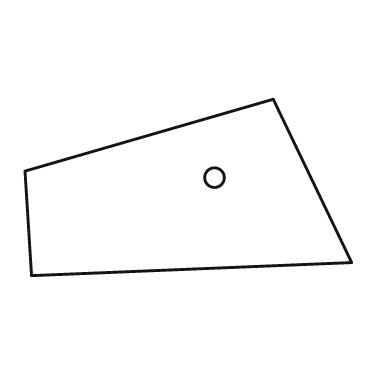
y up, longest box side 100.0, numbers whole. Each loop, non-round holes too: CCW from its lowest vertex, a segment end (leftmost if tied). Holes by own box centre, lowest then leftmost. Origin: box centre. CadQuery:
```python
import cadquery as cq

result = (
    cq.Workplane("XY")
    .moveTo(-48.0, -27.0)
    .lineTo(50.0, -23.0)
    .lineTo(26.0, 27.0)
    .lineTo(-50.0, 5.0)
    .close()
    .moveTo(8.0, 3.0)
    .circle(3.0)
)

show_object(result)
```